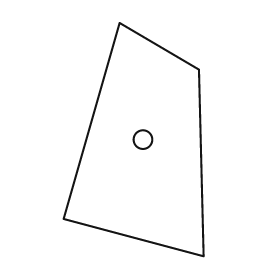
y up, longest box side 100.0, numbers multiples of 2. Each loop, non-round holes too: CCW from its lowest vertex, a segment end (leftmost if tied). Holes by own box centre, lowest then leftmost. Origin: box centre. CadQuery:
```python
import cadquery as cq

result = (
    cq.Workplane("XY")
    .moveTo(30.0, -50.0)
    .lineTo(28.0, 30.0)
    .lineTo(-6.0, 50.0)
    .lineTo(-30.0, -34.0)
    .close()
    .moveTo(4.0, 0.0)
    .circle(4.0)
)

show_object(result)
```